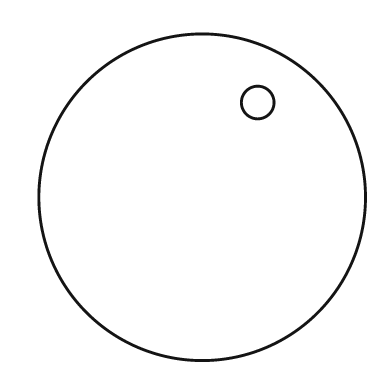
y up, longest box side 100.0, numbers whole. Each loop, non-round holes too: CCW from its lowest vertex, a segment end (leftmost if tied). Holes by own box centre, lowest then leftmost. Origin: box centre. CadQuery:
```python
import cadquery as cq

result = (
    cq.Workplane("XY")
    .moveTo(0.0, 0.0)
    .circle(50.0)
    .moveTo(17.0, 29.0)
    .circle(5.0)
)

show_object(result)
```